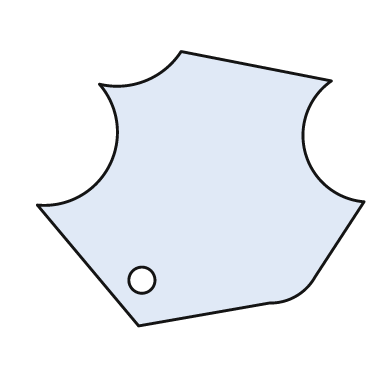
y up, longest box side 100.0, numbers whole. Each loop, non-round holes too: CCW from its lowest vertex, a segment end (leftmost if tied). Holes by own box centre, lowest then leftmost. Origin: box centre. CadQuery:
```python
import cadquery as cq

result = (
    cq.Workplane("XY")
    .moveTo(-19.0, -42.0)
    .lineTo(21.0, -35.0)
    .threePointArc((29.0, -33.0), (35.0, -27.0))
    .lineTo(50.0, -4.0)
    .threePointArc((32.0, 11.0), (40.0, 33.0))
    .lineTo(-6.0, 42.0)
    .threePointArc((-17.0, 33.0), (-31.0, 32.0))
    .threePointArc((-28.0, 7.0), (-50.0, -5.0))
    .close()
    .moveTo(-18.0, -28.0)
    .circle(4.0)
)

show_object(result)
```